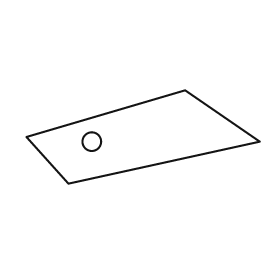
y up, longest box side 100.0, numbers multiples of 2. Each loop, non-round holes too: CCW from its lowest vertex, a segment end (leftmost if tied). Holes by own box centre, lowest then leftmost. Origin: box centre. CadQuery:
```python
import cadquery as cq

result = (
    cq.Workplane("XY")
    .moveTo(-32.0, -20.0)
    .lineTo(50.0, -2.0)
    .lineTo(18.0, 20.0)
    .lineTo(-50.0, 0.0)
    .close()
    .moveTo(-22.0, -2.0)
    .circle(4.0)
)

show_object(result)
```